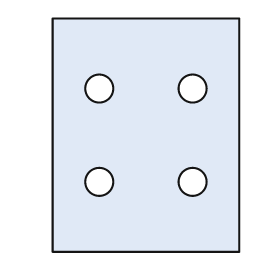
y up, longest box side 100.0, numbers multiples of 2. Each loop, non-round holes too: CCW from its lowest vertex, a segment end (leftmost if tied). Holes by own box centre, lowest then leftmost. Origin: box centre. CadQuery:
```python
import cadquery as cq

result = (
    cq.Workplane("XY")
    .moveTo(-40.0, -50.0)
    .lineTo(40.0, -50.0)
    .lineTo(40.0, 50.0)
    .lineTo(-40.0, 50.0)
    .close()
    .moveTo(-20.0, -20.0)
    .circle(6.0)
    .moveTo(20.0, -20.0)
    .circle(6.0)
    .moveTo(-20.0, 20.0)
    .circle(6.0)
    .moveTo(20.0, 20.0)
    .circle(6.0)
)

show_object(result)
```